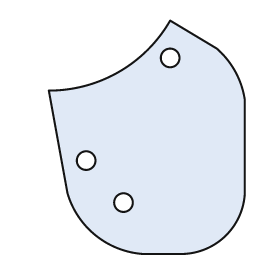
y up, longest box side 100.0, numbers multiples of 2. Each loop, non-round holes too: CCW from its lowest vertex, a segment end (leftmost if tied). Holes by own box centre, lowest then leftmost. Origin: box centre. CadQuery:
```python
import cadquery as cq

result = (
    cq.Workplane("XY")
    .moveTo(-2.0, -50.0)
    .lineTo(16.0, -50.0)
    .threePointArc((34.0, -42.0), (42.0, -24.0))
    .lineTo(42.0, 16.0)
    .threePointArc((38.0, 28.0), (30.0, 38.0))
    .lineTo(10.0, 50.0)
    .threePointArc((-12.0, 28.0), (-42.0, 20.0))
    .lineTo(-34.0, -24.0)
    .threePointArc((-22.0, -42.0), (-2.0, -50.0))
    .close()
    .moveTo(-10.0, -28.0)
    .circle(4.0)
    .moveTo(-26.0, -10.0)
    .circle(4.0)
    .moveTo(10.0, 34.0)
    .circle(4.0)
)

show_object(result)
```